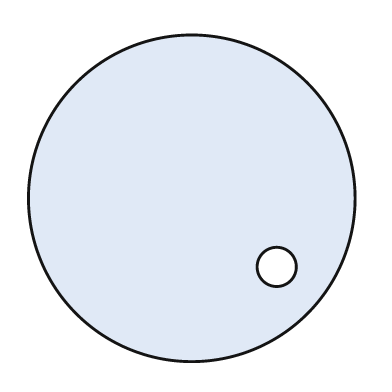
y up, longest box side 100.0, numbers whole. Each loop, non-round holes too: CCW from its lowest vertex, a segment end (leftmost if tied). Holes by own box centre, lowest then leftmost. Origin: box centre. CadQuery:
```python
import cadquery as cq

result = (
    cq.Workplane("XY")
    .moveTo(0.0, 0.0)
    .circle(50.0)
    .moveTo(26.0, -21.0)
    .circle(6.0)
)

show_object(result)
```